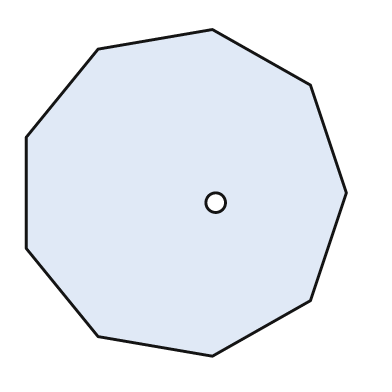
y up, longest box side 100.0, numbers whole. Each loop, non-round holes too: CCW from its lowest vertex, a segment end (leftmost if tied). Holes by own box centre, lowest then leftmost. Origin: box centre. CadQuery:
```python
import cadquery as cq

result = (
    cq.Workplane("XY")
    .moveTo(8.0, -50.0)
    .lineTo(38.0, -33.0)
    .lineTo(49.0, 0.0)
    .lineTo(38.0, 33.0)
    .lineTo(8.0, 50.0)
    .lineTo(-27.0, 44.0)
    .lineTo(-49.0, 17.0)
    .lineTo(-49.0, -17.0)
    .lineTo(-27.0, -44.0)
    .close()
    .moveTo(9.0, -3.0)
    .circle(3.0)
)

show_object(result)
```